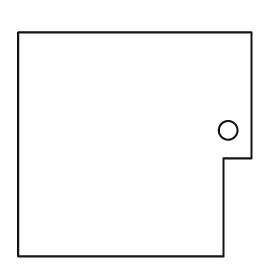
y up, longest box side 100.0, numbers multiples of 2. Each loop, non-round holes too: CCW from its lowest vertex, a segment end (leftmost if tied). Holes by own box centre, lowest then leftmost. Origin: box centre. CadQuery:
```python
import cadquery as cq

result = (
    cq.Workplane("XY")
    .moveTo(-50.0, -48.0)
    .lineTo(38.0, -48.0)
    .lineTo(38.0, -6.0)
    .lineTo(50.0, -6.0)
    .lineTo(50.0, 48.0)
    .lineTo(-50.0, 48.0)
    .close()
    .moveTo(40.0, 6.0)
    .circle(4.0)
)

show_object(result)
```